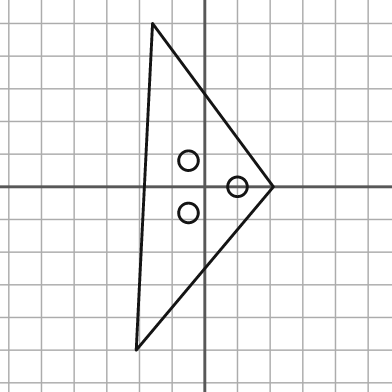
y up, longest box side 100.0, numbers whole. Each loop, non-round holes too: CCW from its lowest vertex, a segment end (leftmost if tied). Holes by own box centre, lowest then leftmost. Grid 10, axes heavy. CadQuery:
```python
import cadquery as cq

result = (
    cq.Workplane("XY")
    .moveTo(-21.0, -50.0)
    .lineTo(21.0, 0.0)
    .lineTo(-16.0, 50.0)
    .close()
    .moveTo(-5.0, -8.0)
    .circle(3.0)
    .moveTo(10.0, 0.0)
    .circle(3.0)
    .moveTo(-5.0, 8.0)
    .circle(3.0)
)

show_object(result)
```